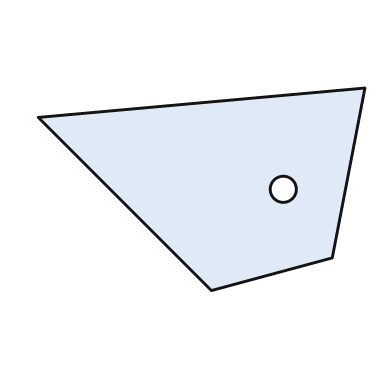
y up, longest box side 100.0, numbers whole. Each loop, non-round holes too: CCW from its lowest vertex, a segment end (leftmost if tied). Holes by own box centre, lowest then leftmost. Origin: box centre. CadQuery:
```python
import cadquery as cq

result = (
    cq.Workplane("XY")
    .moveTo(3.0, -31.0)
    .lineTo(40.0, -21.0)
    .lineTo(50.0, 31.0)
    .lineTo(-50.0, 22.0)
    .close()
    .moveTo(25.0, 0.0)
    .circle(4.0)
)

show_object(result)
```